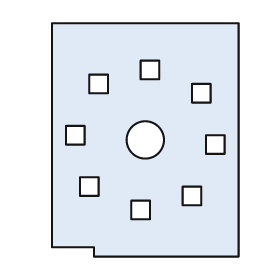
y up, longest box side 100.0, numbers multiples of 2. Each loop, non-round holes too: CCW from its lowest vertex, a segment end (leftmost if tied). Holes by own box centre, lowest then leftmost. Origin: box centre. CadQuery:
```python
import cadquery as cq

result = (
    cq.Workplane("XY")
    .moveTo(-22.0, -50.0)
    .lineTo(40.0, -50.0)
    .lineTo(40.0, 50.0)
    .lineTo(-40.0, 50.0)
    .lineTo(-40.0, -46.0)
    .lineTo(-22.0, -46.0)
    .close()
    .moveTo(-6.0, -34.0)
    .lineTo(2.0, -34.0)
    .lineTo(2.0, -26.0)
    .lineTo(-6.0, -26.0)
    .close()
    .moveTo(16.0, -28.0)
    .lineTo(24.0, -28.0)
    .lineTo(24.0, -20.0)
    .lineTo(16.0, -20.0)
    .close()
    .moveTo(-28.0, -24.0)
    .lineTo(-20.0, -24.0)
    .lineTo(-20.0, -16.0)
    .lineTo(-28.0, -16.0)
    .close()
    .moveTo(26.0, -6.0)
    .lineTo(34.0, -6.0)
    .lineTo(34.0, 2.0)
    .lineTo(26.0, 2.0)
    .close()
    .moveTo(0.0, 0.0)
    .circle(8.0)
    .moveTo(-34.0, -2.0)
    .lineTo(-26.0, -2.0)
    .lineTo(-26.0, 6.0)
    .lineTo(-34.0, 6.0)
    .close()
    .moveTo(20.0, 16.0)
    .lineTo(28.0, 16.0)
    .lineTo(28.0, 24.0)
    .lineTo(20.0, 24.0)
    .close()
    .moveTo(-24.0, 20.0)
    .lineTo(-16.0, 20.0)
    .lineTo(-16.0, 28.0)
    .lineTo(-24.0, 28.0)
    .close()
    .moveTo(-2.0, 26.0)
    .lineTo(6.0, 26.0)
    .lineTo(6.0, 34.0)
    .lineTo(-2.0, 34.0)
    .close()
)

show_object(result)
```